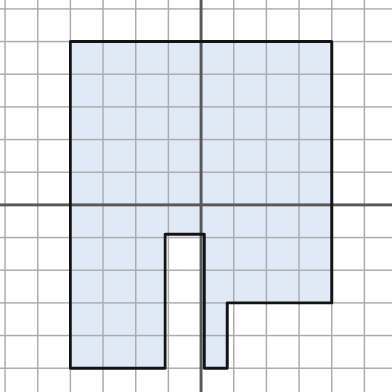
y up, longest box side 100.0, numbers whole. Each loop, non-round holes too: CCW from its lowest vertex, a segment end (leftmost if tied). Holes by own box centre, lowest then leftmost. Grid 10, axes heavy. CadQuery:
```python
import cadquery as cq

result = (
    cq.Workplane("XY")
    .moveTo(-40.0, -50.0)
    .lineTo(-11.0, -50.0)
    .lineTo(-11.0, -9.0)
    .lineTo(1.0, -9.0)
    .lineTo(1.0, -50.0)
    .lineTo(8.0, -50.0)
    .lineTo(8.0, -30.0)
    .lineTo(40.0, -30.0)
    .lineTo(40.0, 50.0)
    .lineTo(-40.0, 50.0)
    .close()
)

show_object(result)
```